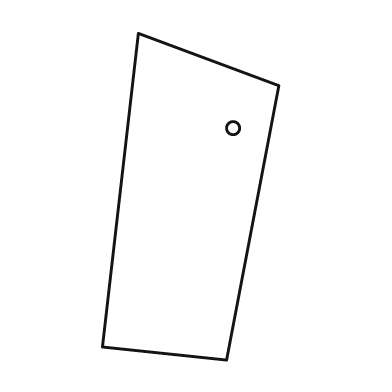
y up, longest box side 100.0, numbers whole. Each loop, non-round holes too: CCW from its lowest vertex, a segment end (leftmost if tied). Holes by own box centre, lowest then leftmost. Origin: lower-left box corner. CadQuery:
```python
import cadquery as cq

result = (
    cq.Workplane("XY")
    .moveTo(38.0, 0.0)
    .lineTo(54.0, 84.0)
    .lineTo(11.0, 100.0)
    .lineTo(0.0, 4.0)
    .close()
    .moveTo(40.0, 71.0)
    .circle(2.0)
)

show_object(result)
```